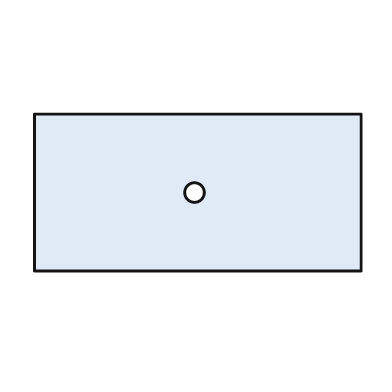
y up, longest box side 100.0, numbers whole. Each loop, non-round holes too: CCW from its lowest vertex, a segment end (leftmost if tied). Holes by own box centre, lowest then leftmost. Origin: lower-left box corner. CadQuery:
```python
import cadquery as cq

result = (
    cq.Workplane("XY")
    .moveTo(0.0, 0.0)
    .lineTo(100.0, 0.0)
    .lineTo(100.0, 48.0)
    .lineTo(0.0, 48.0)
    .close()
    .moveTo(49.0, 24.0)
    .circle(3.0)
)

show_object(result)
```